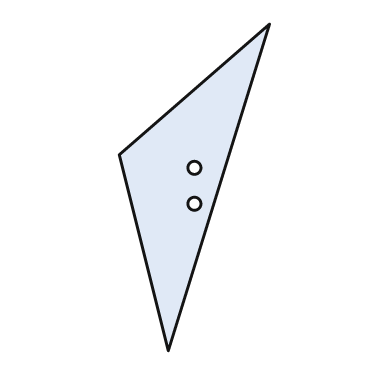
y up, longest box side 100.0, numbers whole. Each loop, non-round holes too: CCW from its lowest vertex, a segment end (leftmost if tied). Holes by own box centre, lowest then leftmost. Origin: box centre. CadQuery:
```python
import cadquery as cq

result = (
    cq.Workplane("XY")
    .moveTo(-8.0, -50.0)
    .lineTo(23.0, 50.0)
    .lineTo(-23.0, 10.0)
    .close()
    .moveTo(0.0, -5.0)
    .circle(2.0)
    .moveTo(0.0, 6.0)
    .circle(2.0)
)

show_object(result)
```